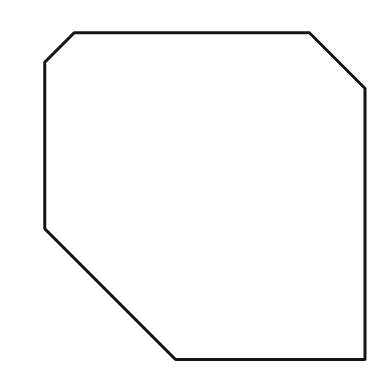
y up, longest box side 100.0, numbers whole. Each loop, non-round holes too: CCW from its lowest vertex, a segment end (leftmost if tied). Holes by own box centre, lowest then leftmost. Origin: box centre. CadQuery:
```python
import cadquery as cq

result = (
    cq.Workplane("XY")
    .moveTo(-9.0, -50.0)
    .lineTo(49.0, -50.0)
    .lineTo(49.0, 33.0)
    .lineTo(32.0, 50.0)
    .lineTo(-40.0, 50.0)
    .lineTo(-49.0, 41.0)
    .lineTo(-49.0, -10.0)
    .close()
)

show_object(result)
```